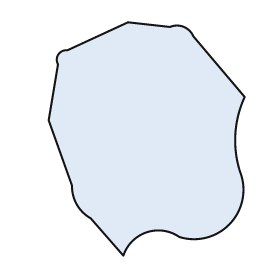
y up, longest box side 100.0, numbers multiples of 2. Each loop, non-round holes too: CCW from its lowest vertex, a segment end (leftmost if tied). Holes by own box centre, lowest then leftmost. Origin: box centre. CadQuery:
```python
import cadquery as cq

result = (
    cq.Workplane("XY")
    .moveTo(-10.0, -50.0)
    .threePointArc((0.0, -40.0), (14.0, -42.0))
    .threePointArc((36.0, -36.0), (40.0, -14.0))
    .threePointArc((38.0, 2.0), (42.0, 18.0))
    .lineTo(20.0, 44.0)
    .threePointArc((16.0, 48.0), (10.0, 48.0))
    .lineTo(-8.0, 50.0)
    .lineTo(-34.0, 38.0)
    .threePointArc((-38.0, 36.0), (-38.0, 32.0))
    .lineTo(-42.0, 8.0)
    .lineTo(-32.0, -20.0)
    .threePointArc((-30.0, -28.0), (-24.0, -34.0))
    .close()
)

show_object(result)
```